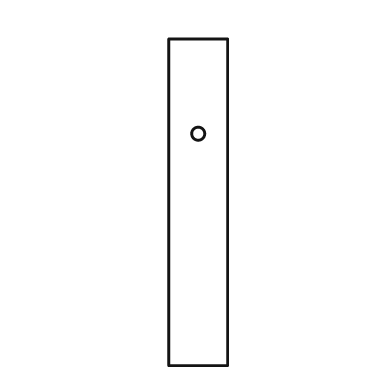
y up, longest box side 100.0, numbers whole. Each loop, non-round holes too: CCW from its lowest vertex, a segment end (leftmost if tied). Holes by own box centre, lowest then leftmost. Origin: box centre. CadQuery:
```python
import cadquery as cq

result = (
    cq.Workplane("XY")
    .moveTo(-9.0, -50.0)
    .lineTo(9.0, -50.0)
    .lineTo(9.0, 50.0)
    .lineTo(-9.0, 50.0)
    .close()
    .moveTo(0.0, 21.0)
    .circle(2.0)
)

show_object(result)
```